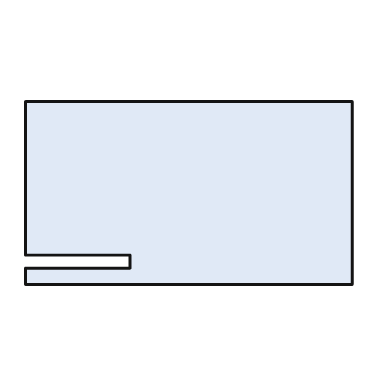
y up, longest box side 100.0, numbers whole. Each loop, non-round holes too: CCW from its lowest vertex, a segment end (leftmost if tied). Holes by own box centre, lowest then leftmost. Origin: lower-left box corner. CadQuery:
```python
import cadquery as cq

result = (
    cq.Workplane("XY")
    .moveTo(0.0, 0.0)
    .lineTo(100.0, 0.0)
    .lineTo(100.0, 56.0)
    .lineTo(0.0, 56.0)
    .lineTo(0.0, 9.0)
    .lineTo(32.0, 9.0)
    .lineTo(32.0, 5.0)
    .lineTo(0.0, 5.0)
    .close()
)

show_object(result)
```